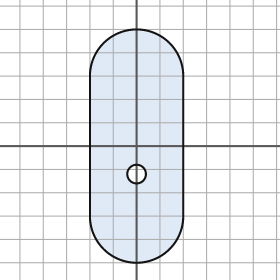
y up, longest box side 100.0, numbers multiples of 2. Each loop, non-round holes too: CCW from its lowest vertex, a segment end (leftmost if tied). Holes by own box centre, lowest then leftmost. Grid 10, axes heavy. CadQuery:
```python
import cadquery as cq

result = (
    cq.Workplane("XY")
    .moveTo(-20.0, -30.0)
    .threePointArc((0.0, -50.0), (20.0, -30.0))
    .lineTo(20.0, 30.0)
    .threePointArc((0.0, 50.0), (-20.0, 30.0))
    .close()
    .moveTo(0.0, -12.0)
    .circle(4.0)
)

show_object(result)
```